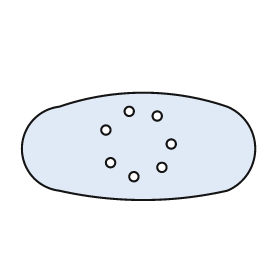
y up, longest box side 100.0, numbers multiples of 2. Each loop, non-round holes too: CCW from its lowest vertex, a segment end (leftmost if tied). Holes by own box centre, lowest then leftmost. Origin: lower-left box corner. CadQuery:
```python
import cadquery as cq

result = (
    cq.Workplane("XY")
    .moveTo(16.0, 4.0)
    .threePointArc((52.0, 0.0), (88.0, 4.0))
    .threePointArc((100.0, 22.0), (88.0, 40.0))
    .threePointArc((52.0, 46.0), (16.0, 40.0))
    .threePointArc((0.0, 22.0), (16.0, 4.0))
    .close()
    .moveTo(48.0, 10.0)
    .circle(2.0)
    .moveTo(60.0, 14.0)
    .circle(2.0)
    .moveTo(38.0, 16.0)
    .circle(2.0)
    .moveTo(64.0, 24.0)
    .circle(2.0)
    .moveTo(36.0, 30.0)
    .circle(2.0)
    .moveTo(58.0, 36.0)
    .circle(2.0)
    .moveTo(46.0, 38.0)
    .circle(2.0)
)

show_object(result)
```